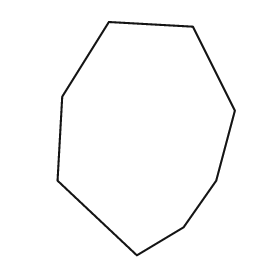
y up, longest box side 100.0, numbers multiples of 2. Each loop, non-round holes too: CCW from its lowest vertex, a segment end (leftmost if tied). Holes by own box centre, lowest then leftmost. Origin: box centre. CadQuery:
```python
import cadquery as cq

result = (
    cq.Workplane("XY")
    .moveTo(-4.0, -50.0)
    .lineTo(16.0, -38.0)
    .lineTo(30.0, -18.0)
    .lineTo(38.0, 12.0)
    .lineTo(20.0, 48.0)
    .lineTo(-16.0, 50.0)
    .lineTo(-36.0, 18.0)
    .lineTo(-38.0, -18.0)
    .close()
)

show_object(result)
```